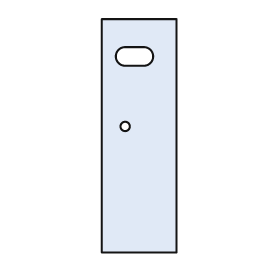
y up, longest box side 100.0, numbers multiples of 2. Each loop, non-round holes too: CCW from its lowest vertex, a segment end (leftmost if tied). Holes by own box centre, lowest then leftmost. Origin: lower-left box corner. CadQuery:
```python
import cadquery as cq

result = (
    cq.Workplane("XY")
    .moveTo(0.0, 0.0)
    .lineTo(32.0, 0.0)
    .lineTo(32.0, 100.0)
    .lineTo(0.0, 100.0)
    .close()
    .moveTo(10.0, 54.0)
    .circle(2.0)
    .moveTo(10.0, 80.0)
    .lineTo(18.0, 80.0)
    .threePointArc((22.0, 84.0), (18.0, 88.0))
    .lineTo(10.0, 88.0)
    .threePointArc((6.0, 84.0), (10.0, 80.0))
    .close()
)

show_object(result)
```